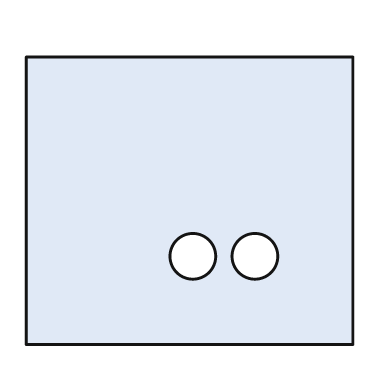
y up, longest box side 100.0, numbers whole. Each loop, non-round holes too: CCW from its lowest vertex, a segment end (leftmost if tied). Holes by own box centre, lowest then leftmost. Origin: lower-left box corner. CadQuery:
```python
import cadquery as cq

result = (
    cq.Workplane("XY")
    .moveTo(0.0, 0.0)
    .lineTo(100.0, 0.0)
    .lineTo(100.0, 88.0)
    .lineTo(0.0, 88.0)
    .close()
    .moveTo(51.0, 27.0)
    .circle(7.0)
    .moveTo(70.0, 27.0)
    .circle(7.0)
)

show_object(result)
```